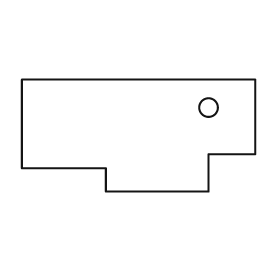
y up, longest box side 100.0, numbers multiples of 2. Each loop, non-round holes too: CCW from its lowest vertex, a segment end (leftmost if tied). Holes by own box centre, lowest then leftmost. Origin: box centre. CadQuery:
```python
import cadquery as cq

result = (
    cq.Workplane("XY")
    .moveTo(-14.0, -24.0)
    .lineTo(30.0, -24.0)
    .lineTo(30.0, -8.0)
    .lineTo(50.0, -8.0)
    .lineTo(50.0, 24.0)
    .lineTo(-50.0, 24.0)
    .lineTo(-50.0, -14.0)
    .lineTo(-14.0, -14.0)
    .close()
    .moveTo(30.0, 12.0)
    .circle(4.0)
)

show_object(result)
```